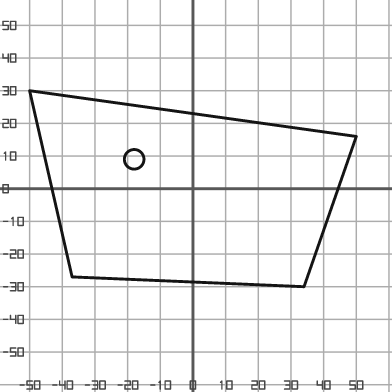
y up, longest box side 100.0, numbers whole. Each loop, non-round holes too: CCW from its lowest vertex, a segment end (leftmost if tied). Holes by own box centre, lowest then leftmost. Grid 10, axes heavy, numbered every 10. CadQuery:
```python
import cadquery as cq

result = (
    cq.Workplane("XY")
    .moveTo(34.0, -30.0)
    .lineTo(50.0, 16.0)
    .lineTo(-50.0, 30.0)
    .lineTo(-37.0, -27.0)
    .close()
    .moveTo(-18.0, 9.0)
    .circle(3.0)
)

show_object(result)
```